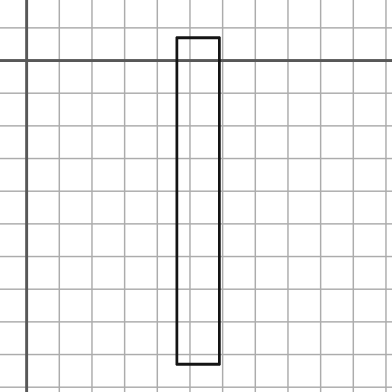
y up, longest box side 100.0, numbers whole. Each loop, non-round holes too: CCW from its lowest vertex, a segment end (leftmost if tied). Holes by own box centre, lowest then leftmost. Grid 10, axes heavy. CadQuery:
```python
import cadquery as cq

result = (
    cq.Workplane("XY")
    .moveTo(46.0, -93.0)
    .lineTo(59.0, -93.0)
    .lineTo(59.0, 7.0)
    .lineTo(46.0, 7.0)
    .close()
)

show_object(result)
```